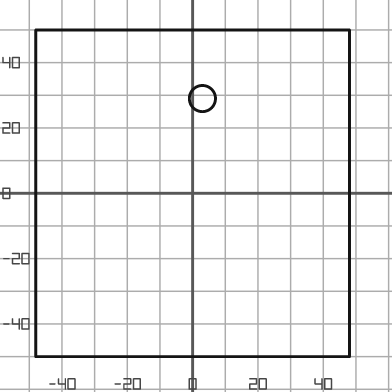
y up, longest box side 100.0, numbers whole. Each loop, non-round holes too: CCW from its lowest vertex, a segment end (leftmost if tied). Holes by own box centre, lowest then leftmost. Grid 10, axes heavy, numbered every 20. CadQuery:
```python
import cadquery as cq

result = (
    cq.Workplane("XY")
    .moveTo(-48.0, -50.0)
    .lineTo(48.0, -50.0)
    .lineTo(48.0, 50.0)
    .lineTo(-48.0, 50.0)
    .close()
    .moveTo(3.0, 29.0)
    .circle(4.0)
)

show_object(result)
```